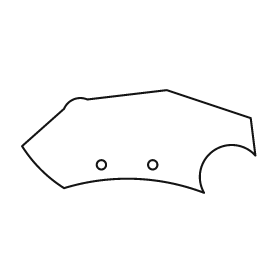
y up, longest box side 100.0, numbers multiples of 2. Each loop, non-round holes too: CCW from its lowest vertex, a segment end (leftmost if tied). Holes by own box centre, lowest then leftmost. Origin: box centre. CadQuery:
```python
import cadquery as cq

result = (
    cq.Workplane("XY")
    .moveTo(28.0, -22.0)
    .threePointArc((32.0, -4.0), (50.0, -6.0))
    .lineTo(48.0, 10.0)
    .lineTo(12.0, 22.0)
    .lineTo(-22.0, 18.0)
    .threePointArc((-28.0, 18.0), (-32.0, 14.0))
    .lineTo(-50.0, -2.0)
    .threePointArc((-42.0, -12.0), (-32.0, -20.0))
    .threePointArc((-2.0, -16.0), (28.0, -22.0))
    .close()
    .moveTo(-16.0, -10.0)
    .circle(2.0)
    .moveTo(6.0, -10.0)
    .circle(2.0)
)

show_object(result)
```